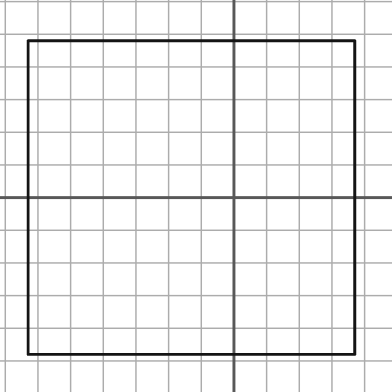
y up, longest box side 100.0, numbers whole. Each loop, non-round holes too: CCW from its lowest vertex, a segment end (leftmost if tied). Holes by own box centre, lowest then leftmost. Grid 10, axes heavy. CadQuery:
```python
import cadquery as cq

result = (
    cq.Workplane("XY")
    .moveTo(-63.0, -48.0)
    .lineTo(37.0, -48.0)
    .lineTo(37.0, 48.0)
    .lineTo(-63.0, 48.0)
    .close()
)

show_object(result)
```